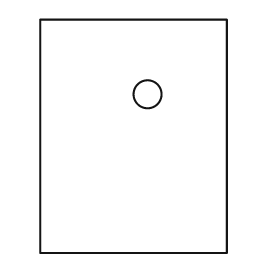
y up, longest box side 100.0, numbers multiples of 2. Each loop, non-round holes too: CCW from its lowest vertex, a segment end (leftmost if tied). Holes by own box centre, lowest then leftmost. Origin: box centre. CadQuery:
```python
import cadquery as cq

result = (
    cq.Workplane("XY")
    .moveTo(-40.0, -50.0)
    .lineTo(40.0, -50.0)
    .lineTo(40.0, 50.0)
    .lineTo(-40.0, 50.0)
    .close()
    .moveTo(6.0, 18.0)
    .circle(6.0)
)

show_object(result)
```